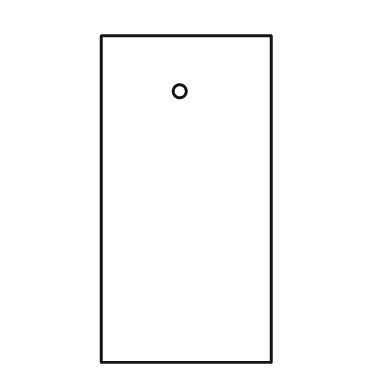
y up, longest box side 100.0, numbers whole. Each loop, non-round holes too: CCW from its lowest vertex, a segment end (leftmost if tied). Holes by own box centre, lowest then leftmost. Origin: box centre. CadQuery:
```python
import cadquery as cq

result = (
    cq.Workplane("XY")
    .moveTo(-26.0, -50.0)
    .lineTo(26.0, -50.0)
    .lineTo(26.0, 50.0)
    .lineTo(-26.0, 50.0)
    .close()
    .moveTo(-2.0, 33.0)
    .circle(2.0)
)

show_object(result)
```